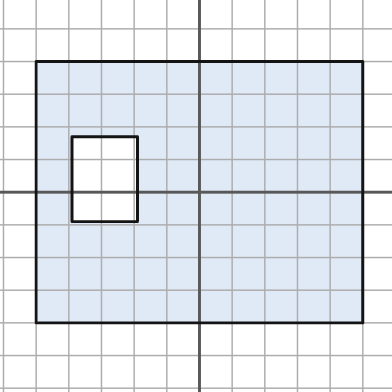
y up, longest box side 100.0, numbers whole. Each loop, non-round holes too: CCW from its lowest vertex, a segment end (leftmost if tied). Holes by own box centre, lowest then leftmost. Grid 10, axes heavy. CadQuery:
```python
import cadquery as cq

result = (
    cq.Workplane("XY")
    .moveTo(-50.0, -40.0)
    .lineTo(50.0, -40.0)
    .lineTo(50.0, 40.0)
    .lineTo(-50.0, 40.0)
    .close()
    .moveTo(-39.0, -9.0)
    .lineTo(-19.0, -9.0)
    .lineTo(-19.0, 17.0)
    .lineTo(-39.0, 17.0)
    .close()
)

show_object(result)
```